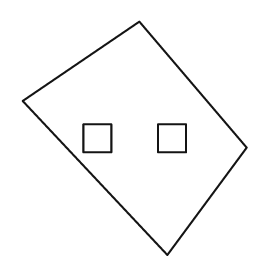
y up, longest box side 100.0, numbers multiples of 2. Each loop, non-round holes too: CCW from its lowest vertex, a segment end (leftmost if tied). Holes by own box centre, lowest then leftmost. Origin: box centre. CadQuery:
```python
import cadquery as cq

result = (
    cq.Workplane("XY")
    .moveTo(14.0, -50.0)
    .lineTo(48.0, -4.0)
    .lineTo(2.0, 50.0)
    .lineTo(-48.0, 16.0)
    .close()
    .moveTo(-22.0, -6.0)
    .lineTo(-10.0, -6.0)
    .lineTo(-10.0, 6.0)
    .lineTo(-22.0, 6.0)
    .close()
    .moveTo(10.0, -6.0)
    .lineTo(22.0, -6.0)
    .lineTo(22.0, 6.0)
    .lineTo(10.0, 6.0)
    .close()
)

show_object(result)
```